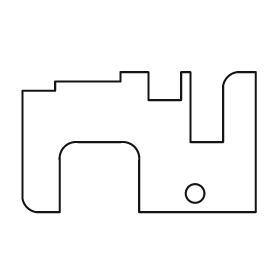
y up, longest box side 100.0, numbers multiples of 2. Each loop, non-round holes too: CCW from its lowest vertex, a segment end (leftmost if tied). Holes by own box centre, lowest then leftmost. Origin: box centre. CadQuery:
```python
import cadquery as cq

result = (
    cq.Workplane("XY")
    .moveTo(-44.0, -30.0)
    .lineTo(-34.0, -30.0)
    .lineTo(-34.0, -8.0)
    .threePointArc((-32.0, -2.0), (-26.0, 0.0))
    .lineTo(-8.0, 0.0)
    .threePointArc((-2.0, -2.0), (0.0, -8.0))
    .lineTo(0.0, -30.0)
    .lineTo(50.0, -30.0)
    .lineTo(50.0, 30.0)
    .lineTo(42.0, 30.0)
    .threePointArc((38.0, 28.0), (36.0, 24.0))
    .lineTo(36.0, 0.0)
    .lineTo(22.0, 0.0)
    .lineTo(22.0, 30.0)
    .lineTo(18.0, 30.0)
    .lineTo(18.0, 18.0)
    .lineTo(4.0, 18.0)
    .lineTo(4.0, 30.0)
    .lineTo(-8.0, 30.0)
    .lineTo(-8.0, 26.0)
    .lineTo(-36.0, 26.0)
    .lineTo(-36.0, 22.0)
    .lineTo(-50.0, 22.0)
    .lineTo(-50.0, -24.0)
    .threePointArc((-48.0, -28.0), (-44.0, -30.0))
    .close()
    .moveTo(24.0, -22.0)
    .circle(4.0)
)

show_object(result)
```